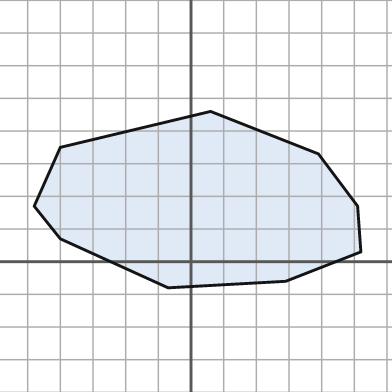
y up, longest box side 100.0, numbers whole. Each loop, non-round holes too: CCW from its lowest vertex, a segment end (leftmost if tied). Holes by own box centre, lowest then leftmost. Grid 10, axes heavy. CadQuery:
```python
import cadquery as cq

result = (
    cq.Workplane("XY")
    .moveTo(-7.0, -8.0)
    .lineTo(29.0, -6.0)
    .lineTo(52.0, 3.0)
    .lineTo(51.0, 17.0)
    .lineTo(39.0, 33.0)
    .lineTo(6.0, 46.0)
    .lineTo(-40.0, 35.0)
    .lineTo(-48.0, 17.0)
    .lineTo(-40.0, 7.0)
    .close()
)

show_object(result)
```